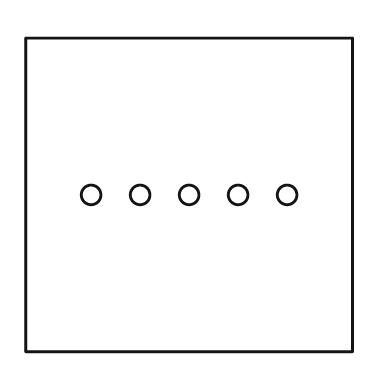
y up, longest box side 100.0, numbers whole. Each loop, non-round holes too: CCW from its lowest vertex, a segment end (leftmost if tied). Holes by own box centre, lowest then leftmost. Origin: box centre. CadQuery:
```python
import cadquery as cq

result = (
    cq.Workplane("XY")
    .moveTo(-50.0, -48.0)
    .lineTo(50.0, -48.0)
    .lineTo(50.0, 48.0)
    .lineTo(-50.0, 48.0)
    .close()
    .moveTo(-30.0, 0.0)
    .circle(3.0)
    .moveTo(-15.0, 0.0)
    .circle(3.0)
    .moveTo(0.0, 0.0)
    .circle(3.0)
    .moveTo(15.0, 0.0)
    .circle(3.0)
    .moveTo(30.0, 0.0)
    .circle(3.0)
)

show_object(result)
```